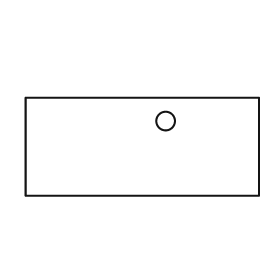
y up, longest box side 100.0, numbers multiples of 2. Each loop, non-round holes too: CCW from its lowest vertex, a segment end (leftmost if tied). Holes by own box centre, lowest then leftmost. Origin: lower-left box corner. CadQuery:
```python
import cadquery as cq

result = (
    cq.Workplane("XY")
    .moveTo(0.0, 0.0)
    .lineTo(100.0, 0.0)
    .lineTo(100.0, 42.0)
    .lineTo(0.0, 42.0)
    .close()
    .moveTo(60.0, 32.0)
    .circle(4.0)
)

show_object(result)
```